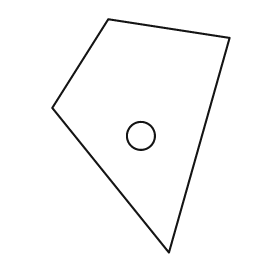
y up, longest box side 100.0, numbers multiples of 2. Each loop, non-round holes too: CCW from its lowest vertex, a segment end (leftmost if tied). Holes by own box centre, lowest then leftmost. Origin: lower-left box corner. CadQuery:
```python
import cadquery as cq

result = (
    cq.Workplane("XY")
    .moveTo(50.0, 0.0)
    .lineTo(76.0, 92.0)
    .lineTo(24.0, 100.0)
    .lineTo(0.0, 62.0)
    .close()
    .moveTo(38.0, 50.0)
    .circle(6.0)
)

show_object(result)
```